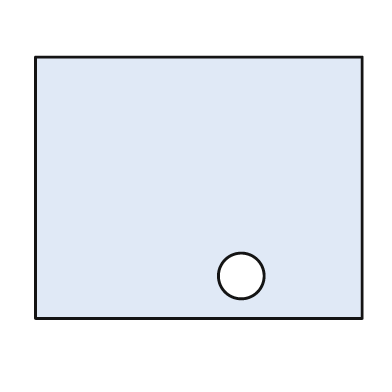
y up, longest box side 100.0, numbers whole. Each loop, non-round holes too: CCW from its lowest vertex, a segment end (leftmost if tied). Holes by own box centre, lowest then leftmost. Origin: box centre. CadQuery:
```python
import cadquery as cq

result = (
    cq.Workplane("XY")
    .moveTo(-50.0, -40.0)
    .lineTo(50.0, -40.0)
    .lineTo(50.0, 40.0)
    .lineTo(-50.0, 40.0)
    .close()
    .moveTo(13.0, -27.0)
    .circle(7.0)
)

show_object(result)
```